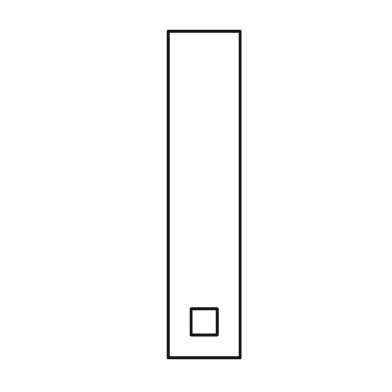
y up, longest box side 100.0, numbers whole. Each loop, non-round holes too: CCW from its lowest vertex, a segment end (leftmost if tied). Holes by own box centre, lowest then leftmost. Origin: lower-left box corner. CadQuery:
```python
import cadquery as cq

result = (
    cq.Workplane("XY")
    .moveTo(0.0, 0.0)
    .lineTo(22.0, 0.0)
    .lineTo(22.0, 100.0)
    .lineTo(0.0, 100.0)
    .close()
    .moveTo(7.0, 7.0)
    .lineTo(15.0, 7.0)
    .lineTo(15.0, 15.0)
    .lineTo(7.0, 15.0)
    .close()
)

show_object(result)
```